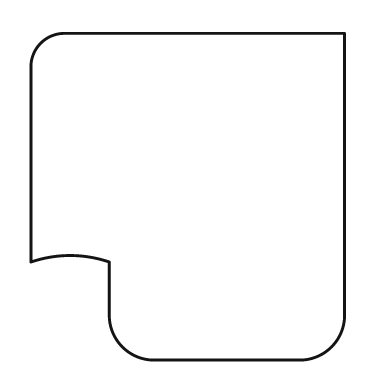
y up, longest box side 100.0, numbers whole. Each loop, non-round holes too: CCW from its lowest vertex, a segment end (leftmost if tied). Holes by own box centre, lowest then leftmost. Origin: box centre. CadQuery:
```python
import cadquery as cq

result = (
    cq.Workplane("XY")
    .moveTo(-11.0, -50.0)
    .lineTo(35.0, -50.0)
    .threePointArc((44.0, -46.0), (48.0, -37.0))
    .lineTo(48.0, 50.0)
    .lineTo(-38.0, 50.0)
    .threePointArc((-45.0, 47.0), (-48.0, 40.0))
    .lineTo(-48.0, -20.0)
    .threePointArc((-36.0, -18.0), (-24.0, -20.0))
    .lineTo(-24.0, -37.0)
    .threePointArc((-20.0, -46.0), (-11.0, -50.0))
    .close()
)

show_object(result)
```